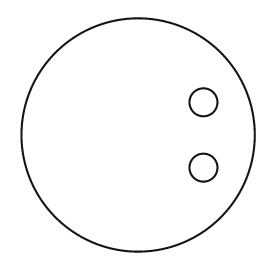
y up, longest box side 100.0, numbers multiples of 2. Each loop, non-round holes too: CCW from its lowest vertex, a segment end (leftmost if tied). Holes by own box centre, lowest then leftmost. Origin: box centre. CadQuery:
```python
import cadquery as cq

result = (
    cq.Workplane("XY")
    .moveTo(0.0, 0.0)
    .circle(50.0)
    .moveTo(28.0, -14.0)
    .circle(6.0)
    .moveTo(28.0, 14.0)
    .circle(6.0)
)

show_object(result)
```